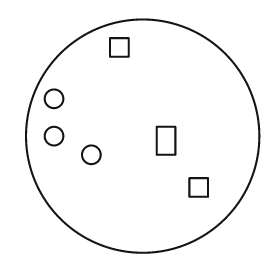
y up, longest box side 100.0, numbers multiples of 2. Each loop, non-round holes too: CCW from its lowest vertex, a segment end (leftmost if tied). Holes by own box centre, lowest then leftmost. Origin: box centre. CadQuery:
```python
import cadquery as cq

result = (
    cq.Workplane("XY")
    .moveTo(0.0, 0.0)
    .circle(50.0)
    .moveTo(20.0, -26.0)
    .lineTo(28.0, -26.0)
    .lineTo(28.0, -18.0)
    .lineTo(20.0, -18.0)
    .close()
    .moveTo(-22.0, -8.0)
    .circle(4.0)
    .moveTo(6.0, -8.0)
    .lineTo(14.0, -8.0)
    .lineTo(14.0, 4.0)
    .lineTo(6.0, 4.0)
    .close()
    .moveTo(-38.0, 0.0)
    .circle(4.0)
    .moveTo(-38.0, 16.0)
    .circle(4.0)
    .moveTo(-14.0, 34.0)
    .lineTo(-6.0, 34.0)
    .lineTo(-6.0, 42.0)
    .lineTo(-14.0, 42.0)
    .close()
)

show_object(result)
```